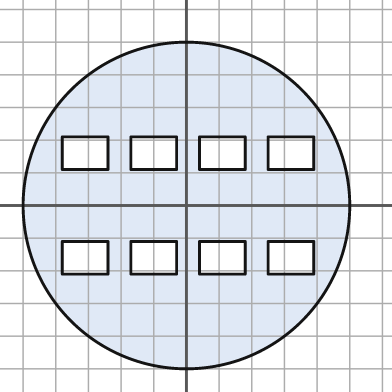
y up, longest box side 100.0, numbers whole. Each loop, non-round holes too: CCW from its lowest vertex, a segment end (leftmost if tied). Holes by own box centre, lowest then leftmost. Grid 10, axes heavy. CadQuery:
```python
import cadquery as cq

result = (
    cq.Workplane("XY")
    .moveTo(0.0, 0.0)
    .circle(50.0)
    .moveTo(-38.0, -21.0)
    .lineTo(-24.0, -21.0)
    .lineTo(-24.0, -11.0)
    .lineTo(-38.0, -11.0)
    .close()
    .moveTo(-17.0, -21.0)
    .lineTo(-3.0, -21.0)
    .lineTo(-3.0, -11.0)
    .lineTo(-17.0, -11.0)
    .close()
    .moveTo(4.0, -21.0)
    .lineTo(18.0, -21.0)
    .lineTo(18.0, -11.0)
    .lineTo(4.0, -11.0)
    .close()
    .moveTo(25.0, -21.0)
    .lineTo(39.0, -21.0)
    .lineTo(39.0, -11.0)
    .lineTo(25.0, -11.0)
    .close()
    .moveTo(-38.0, 11.0)
    .lineTo(-24.0, 11.0)
    .lineTo(-24.0, 21.0)
    .lineTo(-38.0, 21.0)
    .close()
    .moveTo(-17.0, 11.0)
    .lineTo(-3.0, 11.0)
    .lineTo(-3.0, 21.0)
    .lineTo(-17.0, 21.0)
    .close()
    .moveTo(4.0, 11.0)
    .lineTo(18.0, 11.0)
    .lineTo(18.0, 21.0)
    .lineTo(4.0, 21.0)
    .close()
    .moveTo(25.0, 11.0)
    .lineTo(39.0, 11.0)
    .lineTo(39.0, 21.0)
    .lineTo(25.0, 21.0)
    .close()
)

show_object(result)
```